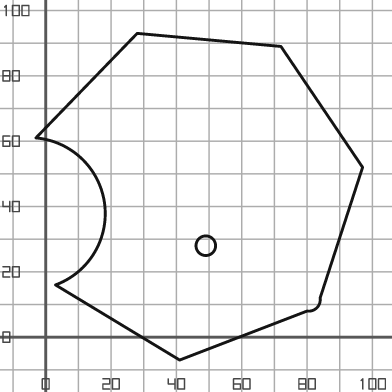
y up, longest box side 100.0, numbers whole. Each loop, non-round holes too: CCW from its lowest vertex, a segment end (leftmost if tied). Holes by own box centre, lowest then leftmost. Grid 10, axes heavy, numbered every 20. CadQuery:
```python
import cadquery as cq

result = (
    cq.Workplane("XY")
    .moveTo(41.0, -7.0)
    .lineTo(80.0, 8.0)
    .threePointArc((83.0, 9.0), (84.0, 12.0))
    .lineTo(97.0, 52.0)
    .lineTo(72.0, 89.0)
    .lineTo(28.0, 93.0)
    .lineTo(-3.0, 61.0)
    .threePointArc((18.0, 41.0), (3.0, 16.0))
    .close()
    .moveTo(49.0, 28.0)
    .circle(3.0)
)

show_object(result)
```